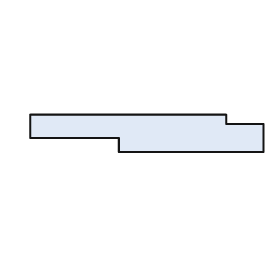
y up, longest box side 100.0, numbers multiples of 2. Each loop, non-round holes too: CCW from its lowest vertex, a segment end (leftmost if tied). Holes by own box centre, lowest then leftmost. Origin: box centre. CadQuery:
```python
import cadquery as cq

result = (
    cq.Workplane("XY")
    .moveTo(-12.0, -8.0)
    .lineTo(50.0, -8.0)
    .lineTo(50.0, 4.0)
    .lineTo(34.0, 4.0)
    .lineTo(34.0, 8.0)
    .lineTo(-50.0, 8.0)
    .lineTo(-50.0, -2.0)
    .lineTo(-12.0, -2.0)
    .close()
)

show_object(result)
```